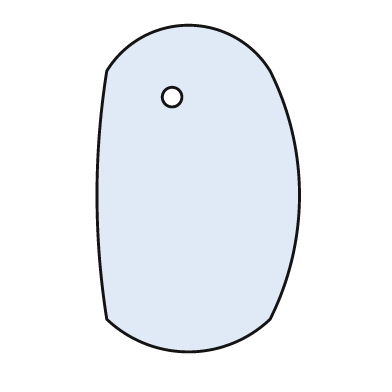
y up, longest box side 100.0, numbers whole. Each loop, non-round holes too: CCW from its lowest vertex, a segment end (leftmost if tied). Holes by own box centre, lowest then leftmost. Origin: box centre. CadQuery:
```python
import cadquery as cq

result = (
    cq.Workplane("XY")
    .moveTo(-28.0, -40.0)
    .threePointArc((-3.0, -50.0), (22.0, -40.0))
    .threePointArc((31.0, -2.0), (22.0, 36.0))
    .threePointArc((-3.0, 50.0), (-28.0, 36.0))
    .threePointArc((-31.0, -2.0), (-28.0, -40.0))
    .close()
    .moveTo(-8.0, 28.0)
    .circle(3.0)
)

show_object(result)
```